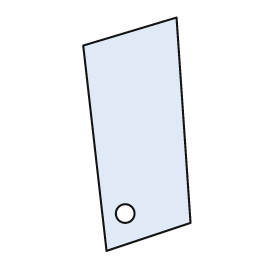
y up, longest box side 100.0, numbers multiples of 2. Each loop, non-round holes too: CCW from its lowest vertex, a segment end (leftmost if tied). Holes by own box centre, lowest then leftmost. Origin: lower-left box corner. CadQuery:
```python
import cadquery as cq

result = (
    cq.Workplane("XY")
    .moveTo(10.0, 0.0)
    .lineTo(46.0, 12.0)
    .lineTo(40.0, 100.0)
    .lineTo(0.0, 88.0)
    .close()
    .moveTo(18.0, 16.0)
    .circle(4.0)
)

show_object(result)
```